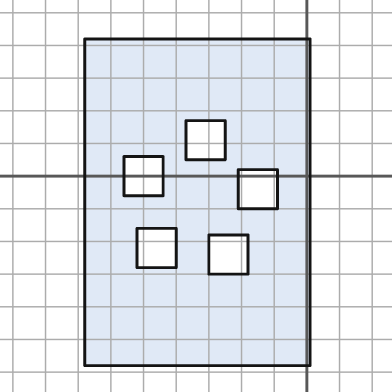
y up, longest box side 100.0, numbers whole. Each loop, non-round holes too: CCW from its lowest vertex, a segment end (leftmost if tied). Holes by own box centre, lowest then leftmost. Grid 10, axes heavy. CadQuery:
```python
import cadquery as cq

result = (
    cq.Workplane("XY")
    .moveTo(-68.0, -58.0)
    .lineTo(1.0, -58.0)
    .lineTo(1.0, 42.0)
    .lineTo(-68.0, 42.0)
    .close()
    .moveTo(-30.0, -30.0)
    .lineTo(-18.0, -30.0)
    .lineTo(-18.0, -18.0)
    .lineTo(-30.0, -18.0)
    .close()
    .moveTo(-52.0, -28.0)
    .lineTo(-40.0, -28.0)
    .lineTo(-40.0, -16.0)
    .lineTo(-52.0, -16.0)
    .close()
    .moveTo(-21.0, -10.0)
    .lineTo(-9.0, -10.0)
    .lineTo(-9.0, 2.0)
    .lineTo(-21.0, 2.0)
    .close()
    .moveTo(-56.0, -6.0)
    .lineTo(-44.0, -6.0)
    .lineTo(-44.0, 6.0)
    .lineTo(-56.0, 6.0)
    .close()
    .moveTo(-37.0, 5.0)
    .lineTo(-25.0, 5.0)
    .lineTo(-25.0, 17.0)
    .lineTo(-37.0, 17.0)
    .close()
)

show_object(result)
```